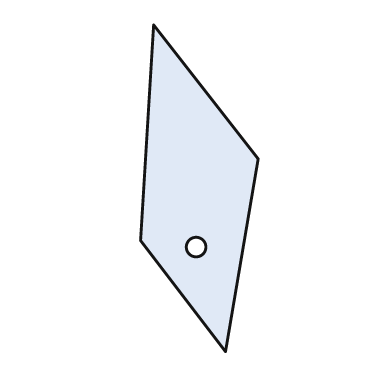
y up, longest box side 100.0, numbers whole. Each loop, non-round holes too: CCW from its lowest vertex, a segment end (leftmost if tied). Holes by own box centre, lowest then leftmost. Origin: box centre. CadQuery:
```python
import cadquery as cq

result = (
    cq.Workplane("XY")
    .moveTo(8.0, -50.0)
    .lineTo(18.0, 9.0)
    .lineTo(-14.0, 50.0)
    .lineTo(-18.0, -16.0)
    .close()
    .moveTo(-1.0, -18.0)
    .circle(3.0)
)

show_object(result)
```